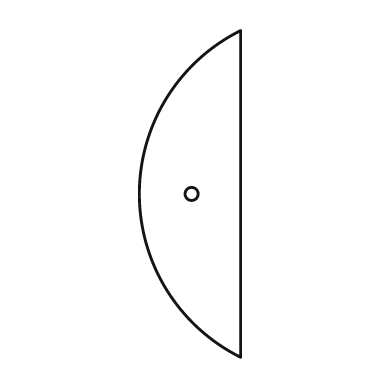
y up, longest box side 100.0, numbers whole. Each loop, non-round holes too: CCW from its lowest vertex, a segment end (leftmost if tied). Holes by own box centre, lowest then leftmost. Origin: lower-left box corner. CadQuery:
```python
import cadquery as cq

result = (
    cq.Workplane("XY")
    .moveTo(31.0, 0.0)
    .lineTo(31.0, 100.0)
    .threePointArc((0.0, 50.0), (31.0, 0.0))
    .close()
    .moveTo(16.0, 50.0)
    .circle(2.0)
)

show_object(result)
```